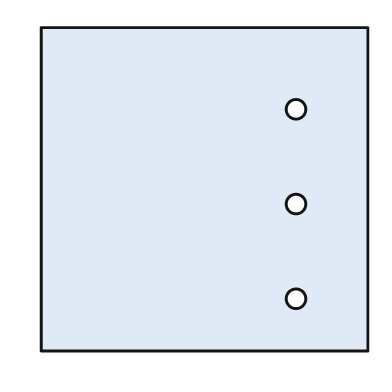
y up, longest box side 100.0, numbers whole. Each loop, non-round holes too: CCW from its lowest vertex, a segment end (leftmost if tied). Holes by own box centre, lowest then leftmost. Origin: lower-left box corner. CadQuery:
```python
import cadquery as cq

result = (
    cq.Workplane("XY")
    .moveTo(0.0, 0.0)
    .lineTo(100.0, 0.0)
    .lineTo(100.0, 99.0)
    .lineTo(0.0, 99.0)
    .close()
    .moveTo(78.0, 16.0)
    .circle(3.0)
    .moveTo(78.0, 45.0)
    .circle(3.0)
    .moveTo(78.0, 74.0)
    .circle(3.0)
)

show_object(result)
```